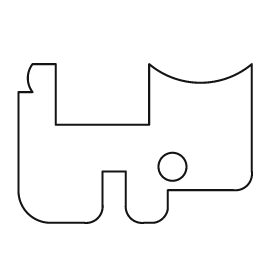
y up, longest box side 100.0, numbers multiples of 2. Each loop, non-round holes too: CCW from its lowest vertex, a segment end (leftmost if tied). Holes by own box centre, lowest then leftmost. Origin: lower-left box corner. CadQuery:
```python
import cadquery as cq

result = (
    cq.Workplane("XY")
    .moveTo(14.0, 0.0)
    .lineTo(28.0, 0.0)
    .threePointArc((34.0, 2.0), (36.0, 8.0))
    .lineTo(36.0, 22.0)
    .lineTo(46.0, 22.0)
    .lineTo(46.0, 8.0)
    .threePointArc((48.0, 2.0), (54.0, 0.0))
    .lineTo(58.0, 0.0)
    .threePointArc((62.0, 2.0), (64.0, 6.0))
    .lineTo(64.0, 14.0)
    .lineTo(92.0, 14.0)
    .threePointArc((98.0, 16.0), (100.0, 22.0))
    .lineTo(100.0, 68.0)
    .threePointArc((78.0, 60.0), (56.0, 68.0))
    .lineTo(56.0, 42.0)
    .lineTo(16.0, 42.0)
    .lineTo(16.0, 68.0)
    .lineTo(6.0, 68.0)
    .threePointArc((4.0, 62.0), (6.0, 56.0))
    .lineTo(0.0, 56.0)
    .lineTo(0.0, 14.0)
    .threePointArc((4.0, 4.0), (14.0, 0.0))
    .close()
    .moveTo(66.0, 24.0)
    .circle(6.0)
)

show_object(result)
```